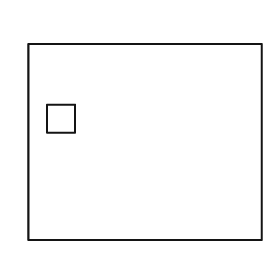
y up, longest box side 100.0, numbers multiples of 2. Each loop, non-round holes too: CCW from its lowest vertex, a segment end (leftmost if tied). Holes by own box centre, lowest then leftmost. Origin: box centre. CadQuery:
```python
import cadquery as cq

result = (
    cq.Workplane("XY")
    .moveTo(-50.0, -42.0)
    .lineTo(50.0, -42.0)
    .lineTo(50.0, 42.0)
    .lineTo(-50.0, 42.0)
    .close()
    .moveTo(-42.0, 4.0)
    .lineTo(-30.0, 4.0)
    .lineTo(-30.0, 16.0)
    .lineTo(-42.0, 16.0)
    .close()
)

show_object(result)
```